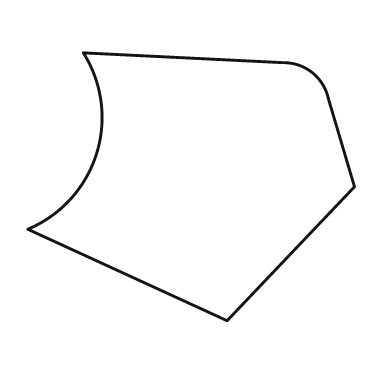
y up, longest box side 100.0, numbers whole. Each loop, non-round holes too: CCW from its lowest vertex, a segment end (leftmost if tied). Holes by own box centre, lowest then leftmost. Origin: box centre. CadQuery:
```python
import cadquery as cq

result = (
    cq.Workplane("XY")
    .moveTo(11.0, -41.0)
    .lineTo(50.0, 0.0)
    .lineTo(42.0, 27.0)
    .threePointArc((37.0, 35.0), (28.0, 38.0))
    .lineTo(-33.0, 41.0)
    .threePointArc((-29.0, 10.0), (-50.0, -13.0))
    .close()
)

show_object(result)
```